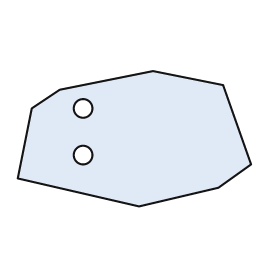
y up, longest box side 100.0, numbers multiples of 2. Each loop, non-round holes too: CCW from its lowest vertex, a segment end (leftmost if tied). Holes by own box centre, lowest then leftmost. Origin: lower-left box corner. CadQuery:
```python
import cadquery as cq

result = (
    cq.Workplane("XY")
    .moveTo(52.0, 0.0)
    .lineTo(86.0, 8.0)
    .lineTo(100.0, 18.0)
    .lineTo(88.0, 52.0)
    .lineTo(58.0, 58.0)
    .lineTo(18.0, 50.0)
    .lineTo(6.0, 42.0)
    .lineTo(0.0, 12.0)
    .close()
    .moveTo(28.0, 22.0)
    .circle(4.0)
    .moveTo(28.0, 42.0)
    .circle(4.0)
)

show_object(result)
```